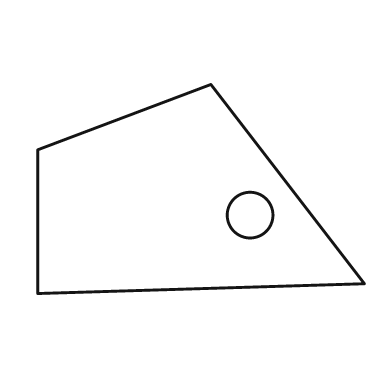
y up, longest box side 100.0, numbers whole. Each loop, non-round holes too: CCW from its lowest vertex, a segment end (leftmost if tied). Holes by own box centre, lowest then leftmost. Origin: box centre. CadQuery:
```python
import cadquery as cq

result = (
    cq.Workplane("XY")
    .moveTo(-50.0, -32.0)
    .lineTo(50.0, -29.0)
    .lineTo(3.0, 32.0)
    .lineTo(-50.0, 12.0)
    .close()
    .moveTo(15.0, -8.0)
    .circle(7.0)
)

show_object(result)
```